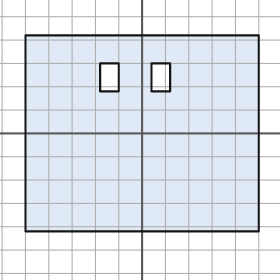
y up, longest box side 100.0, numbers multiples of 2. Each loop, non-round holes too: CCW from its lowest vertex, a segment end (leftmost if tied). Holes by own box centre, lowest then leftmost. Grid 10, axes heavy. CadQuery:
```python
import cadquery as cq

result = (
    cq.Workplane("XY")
    .moveTo(-50.0, -42.0)
    .lineTo(50.0, -42.0)
    .lineTo(50.0, 42.0)
    .lineTo(-50.0, 42.0)
    .close()
    .moveTo(-18.0, 18.0)
    .lineTo(-10.0, 18.0)
    .lineTo(-10.0, 30.0)
    .lineTo(-18.0, 30.0)
    .close()
    .moveTo(4.0, 18.0)
    .lineTo(12.0, 18.0)
    .lineTo(12.0, 30.0)
    .lineTo(4.0, 30.0)
    .close()
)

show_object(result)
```